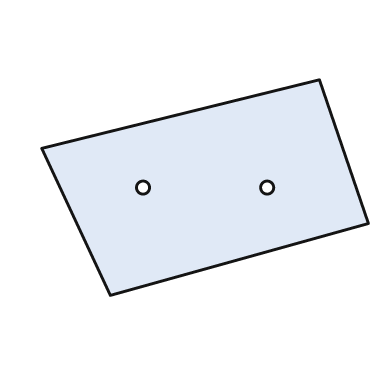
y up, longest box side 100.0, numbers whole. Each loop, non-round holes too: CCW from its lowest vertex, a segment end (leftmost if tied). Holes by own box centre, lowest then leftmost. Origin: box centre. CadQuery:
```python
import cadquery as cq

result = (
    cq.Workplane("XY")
    .moveTo(-29.0, -33.0)
    .lineTo(50.0, -11.0)
    .lineTo(35.0, 33.0)
    .lineTo(-50.0, 12.0)
    .close()
    .moveTo(-19.0, 0.0)
    .circle(2.0)
    .moveTo(19.0, 0.0)
    .circle(2.0)
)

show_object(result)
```